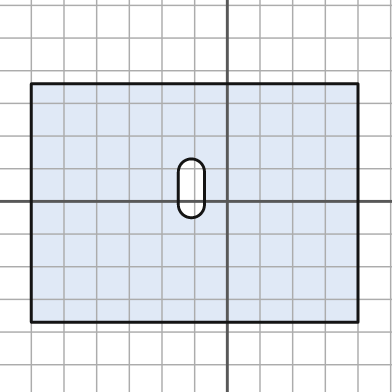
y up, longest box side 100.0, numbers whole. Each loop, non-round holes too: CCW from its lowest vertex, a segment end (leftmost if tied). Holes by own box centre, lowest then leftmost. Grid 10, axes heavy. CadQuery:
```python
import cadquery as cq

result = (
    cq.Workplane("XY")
    .moveTo(-60.0, -37.0)
    .lineTo(40.0, -37.0)
    .lineTo(40.0, 36.0)
    .lineTo(-60.0, 36.0)
    .close()
    .moveTo(-15.0, -1.0)
    .threePointArc((-11.0, -5.0), (-7.0, -1.0))
    .lineTo(-7.0, 9.0)
    .threePointArc((-11.0, 13.0), (-15.0, 9.0))
    .close()
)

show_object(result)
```